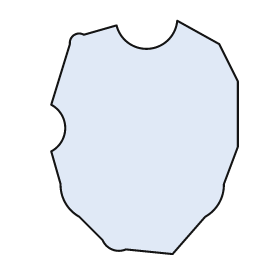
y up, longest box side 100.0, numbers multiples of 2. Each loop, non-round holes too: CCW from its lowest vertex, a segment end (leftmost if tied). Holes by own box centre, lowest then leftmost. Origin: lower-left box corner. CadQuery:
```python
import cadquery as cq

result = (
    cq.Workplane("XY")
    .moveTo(52.0, 0.0)
    .lineTo(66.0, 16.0)
    .threePointArc((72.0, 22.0), (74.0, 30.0))
    .lineTo(80.0, 46.0)
    .lineTo(80.0, 74.0)
    .lineTo(72.0, 90.0)
    .lineTo(54.0, 100.0)
    .threePointArc((42.0, 88.0), (28.0, 98.0))
    .lineTo(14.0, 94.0)
    .threePointArc((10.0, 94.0), (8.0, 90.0))
    .lineTo(0.0, 64.0)
    .threePointArc((6.0, 54.0), (0.0, 44.0))
    .lineTo(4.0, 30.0)
    .threePointArc((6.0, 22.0), (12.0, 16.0))
    .lineTo(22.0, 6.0)
    .threePointArc((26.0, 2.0), (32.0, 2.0))
    .close()
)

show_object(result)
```